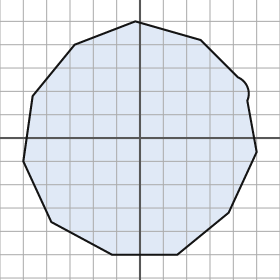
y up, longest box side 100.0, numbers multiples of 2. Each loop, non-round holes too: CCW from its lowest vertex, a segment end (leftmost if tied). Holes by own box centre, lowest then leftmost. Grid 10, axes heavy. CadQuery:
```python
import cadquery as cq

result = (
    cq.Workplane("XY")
    .moveTo(-12.0, -50.0)
    .lineTo(16.0, -50.0)
    .lineTo(38.0, -32.0)
    .lineTo(50.0, -6.0)
    .lineTo(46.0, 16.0)
    .threePointArc((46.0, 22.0), (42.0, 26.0))
    .lineTo(26.0, 42.0)
    .lineTo(-2.0, 50.0)
    .lineTo(-28.0, 40.0)
    .lineTo(-46.0, 18.0)
    .lineTo(-50.0, -10.0)
    .lineTo(-38.0, -36.0)
    .close()
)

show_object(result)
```